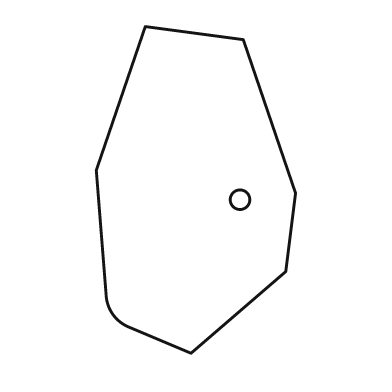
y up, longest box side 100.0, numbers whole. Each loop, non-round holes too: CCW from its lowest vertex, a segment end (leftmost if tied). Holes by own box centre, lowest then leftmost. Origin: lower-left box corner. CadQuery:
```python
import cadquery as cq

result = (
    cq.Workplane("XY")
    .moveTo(29.0, 0.0)
    .lineTo(58.0, 25.0)
    .lineTo(61.0, 49.0)
    .lineTo(45.0, 96.0)
    .lineTo(15.0, 100.0)
    .lineTo(0.0, 56.0)
    .lineTo(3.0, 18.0)
    .threePointArc((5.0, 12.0), (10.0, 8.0))
    .close()
    .moveTo(44.0, 47.0)
    .circle(3.0)
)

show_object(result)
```